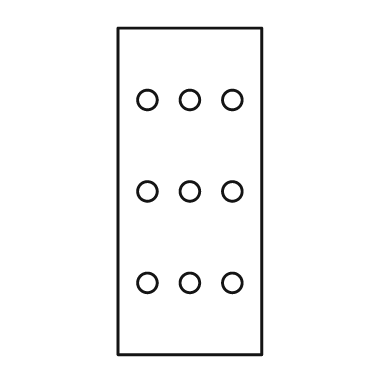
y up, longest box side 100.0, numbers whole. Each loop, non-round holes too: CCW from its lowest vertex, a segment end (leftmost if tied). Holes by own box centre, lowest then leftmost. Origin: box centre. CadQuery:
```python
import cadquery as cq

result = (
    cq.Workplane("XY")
    .moveTo(-22.0, -50.0)
    .lineTo(22.0, -50.0)
    .lineTo(22.0, 50.0)
    .lineTo(-22.0, 50.0)
    .close()
    .moveTo(-13.0, -28.0)
    .circle(3.0)
    .moveTo(0.0, -28.0)
    .circle(3.0)
    .moveTo(13.0, -28.0)
    .circle(3.0)
    .moveTo(-13.0, 0.0)
    .circle(3.0)
    .moveTo(0.0, 0.0)
    .circle(3.0)
    .moveTo(13.0, 0.0)
    .circle(3.0)
    .moveTo(-13.0, 28.0)
    .circle(3.0)
    .moveTo(0.0, 28.0)
    .circle(3.0)
    .moveTo(13.0, 28.0)
    .circle(3.0)
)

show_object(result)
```